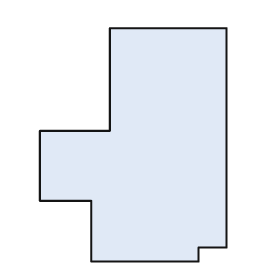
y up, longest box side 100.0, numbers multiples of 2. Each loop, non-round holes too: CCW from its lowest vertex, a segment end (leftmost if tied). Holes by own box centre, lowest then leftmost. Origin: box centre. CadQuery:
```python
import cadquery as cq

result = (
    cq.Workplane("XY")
    .moveTo(-18.0, -50.0)
    .lineTo(28.0, -50.0)
    .lineTo(28.0, -44.0)
    .lineTo(40.0, -44.0)
    .lineTo(40.0, 50.0)
    .lineTo(-10.0, 50.0)
    .lineTo(-10.0, 6.0)
    .lineTo(-40.0, 6.0)
    .lineTo(-40.0, -24.0)
    .lineTo(-18.0, -24.0)
    .close()
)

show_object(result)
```